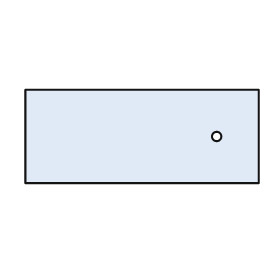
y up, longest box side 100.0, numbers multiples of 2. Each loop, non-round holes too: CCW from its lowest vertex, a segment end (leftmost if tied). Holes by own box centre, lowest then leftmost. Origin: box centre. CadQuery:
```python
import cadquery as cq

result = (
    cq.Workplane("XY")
    .moveTo(-50.0, -20.0)
    .lineTo(50.0, -20.0)
    .lineTo(50.0, 20.0)
    .lineTo(-50.0, 20.0)
    .close()
    .moveTo(32.0, 0.0)
    .circle(2.0)
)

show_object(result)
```